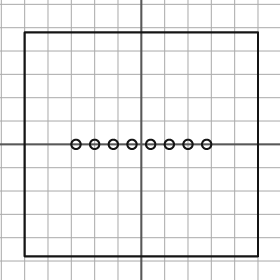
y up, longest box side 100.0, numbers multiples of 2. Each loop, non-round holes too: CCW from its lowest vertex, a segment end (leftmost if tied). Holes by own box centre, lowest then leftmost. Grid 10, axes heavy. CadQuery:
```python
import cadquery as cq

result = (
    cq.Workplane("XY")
    .moveTo(-50.0, -48.0)
    .lineTo(50.0, -48.0)
    .lineTo(50.0, 48.0)
    .lineTo(-50.0, 48.0)
    .close()
    .moveTo(-28.0, 0.0)
    .circle(2.0)
    .moveTo(-20.0, 0.0)
    .circle(2.0)
    .moveTo(-12.0, 0.0)
    .circle(2.0)
    .moveTo(-4.0, 0.0)
    .circle(2.0)
    .moveTo(4.0, 0.0)
    .circle(2.0)
    .moveTo(12.0, 0.0)
    .circle(2.0)
    .moveTo(20.0, 0.0)
    .circle(2.0)
    .moveTo(28.0, 0.0)
    .circle(2.0)
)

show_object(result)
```